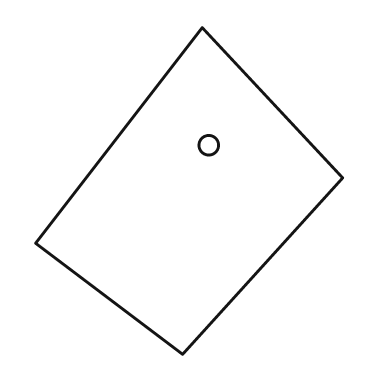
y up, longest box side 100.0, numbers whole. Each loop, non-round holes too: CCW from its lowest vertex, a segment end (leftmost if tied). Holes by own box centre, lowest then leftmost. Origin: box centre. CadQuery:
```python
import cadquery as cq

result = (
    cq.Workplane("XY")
    .moveTo(-2.0, -50.0)
    .lineTo(47.0, 4.0)
    .lineTo(4.0, 50.0)
    .lineTo(-47.0, -16.0)
    .close()
    .moveTo(6.0, 14.0)
    .circle(3.0)
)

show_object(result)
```